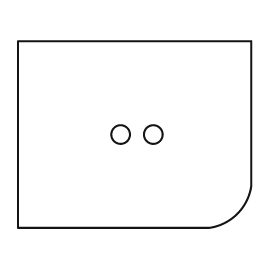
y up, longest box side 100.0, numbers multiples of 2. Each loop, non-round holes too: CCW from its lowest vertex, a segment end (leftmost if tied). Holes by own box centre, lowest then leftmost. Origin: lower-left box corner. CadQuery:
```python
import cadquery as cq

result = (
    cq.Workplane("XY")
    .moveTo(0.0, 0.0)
    .lineTo(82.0, 0.0)
    .threePointArc((94.0, 6.0), (100.0, 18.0))
    .lineTo(100.0, 80.0)
    .lineTo(0.0, 80.0)
    .close()
    .moveTo(44.0, 40.0)
    .circle(4.0)
    .moveTo(58.0, 40.0)
    .circle(4.0)
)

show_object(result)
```